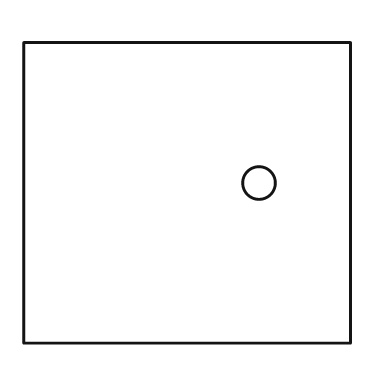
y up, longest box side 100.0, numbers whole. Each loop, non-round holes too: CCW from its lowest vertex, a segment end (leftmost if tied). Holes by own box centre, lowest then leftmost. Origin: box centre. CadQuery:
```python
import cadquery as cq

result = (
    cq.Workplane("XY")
    .moveTo(-50.0, -46.0)
    .lineTo(50.0, -46.0)
    .lineTo(50.0, 46.0)
    .lineTo(-50.0, 46.0)
    .close()
    .moveTo(22.0, 3.0)
    .circle(5.0)
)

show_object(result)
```